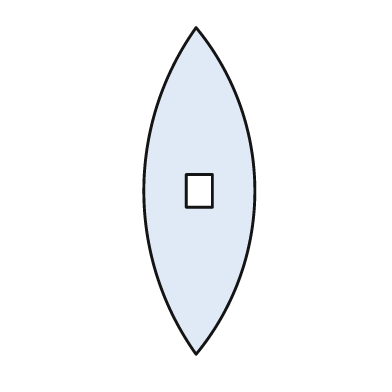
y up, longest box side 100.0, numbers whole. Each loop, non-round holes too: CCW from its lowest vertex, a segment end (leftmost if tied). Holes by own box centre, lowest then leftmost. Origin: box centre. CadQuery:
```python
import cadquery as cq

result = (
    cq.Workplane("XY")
    .moveTo(-1.0, -50.0)
    .threePointArc((17.0, 0.0), (-1.0, 50.0))
    .threePointArc((-17.0, 0.0), (-1.0, -50.0))
    .close()
    .moveTo(-4.0, -5.0)
    .lineTo(4.0, -5.0)
    .lineTo(4.0, 5.0)
    .lineTo(-4.0, 5.0)
    .close()
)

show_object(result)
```